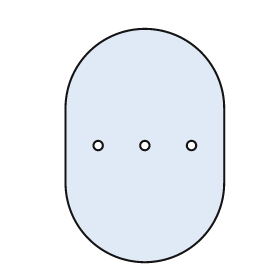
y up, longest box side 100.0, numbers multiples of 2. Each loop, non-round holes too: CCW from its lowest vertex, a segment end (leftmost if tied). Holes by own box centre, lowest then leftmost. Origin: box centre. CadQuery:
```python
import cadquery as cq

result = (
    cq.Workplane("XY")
    .moveTo(-34.0, -16.0)
    .threePointArc((0.0, -50.0), (34.0, -16.0))
    .lineTo(34.0, 16.0)
    .threePointArc((0.0, 50.0), (-34.0, 16.0))
    .close()
    .moveTo(-20.0, 0.0)
    .circle(2.0)
    .moveTo(0.0, 0.0)
    .circle(2.0)
    .moveTo(20.0, 0.0)
    .circle(2.0)
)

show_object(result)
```